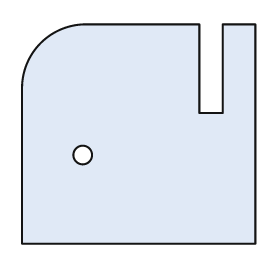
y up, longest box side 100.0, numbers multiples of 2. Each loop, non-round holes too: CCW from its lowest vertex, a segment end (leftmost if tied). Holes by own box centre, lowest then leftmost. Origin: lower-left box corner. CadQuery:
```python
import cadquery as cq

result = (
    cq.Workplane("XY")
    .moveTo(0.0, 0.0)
    .lineTo(100.0, 0.0)
    .lineTo(100.0, 94.0)
    .lineTo(86.0, 94.0)
    .lineTo(86.0, 56.0)
    .lineTo(76.0, 56.0)
    .lineTo(76.0, 94.0)
    .lineTo(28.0, 94.0)
    .threePointArc((8.0, 86.0), (0.0, 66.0))
    .close()
    .moveTo(26.0, 38.0)
    .circle(4.0)
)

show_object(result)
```